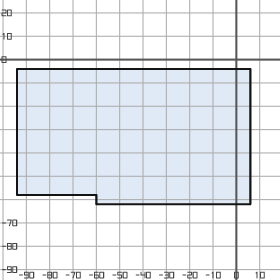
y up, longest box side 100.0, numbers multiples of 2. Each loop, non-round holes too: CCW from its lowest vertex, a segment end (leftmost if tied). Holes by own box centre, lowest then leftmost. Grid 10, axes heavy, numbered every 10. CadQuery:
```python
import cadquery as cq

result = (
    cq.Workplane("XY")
    .moveTo(-60.0, -62.0)
    .lineTo(6.0, -62.0)
    .lineTo(6.0, -4.0)
    .lineTo(-94.0, -4.0)
    .lineTo(-94.0, -58.0)
    .lineTo(-60.0, -58.0)
    .close()
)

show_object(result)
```